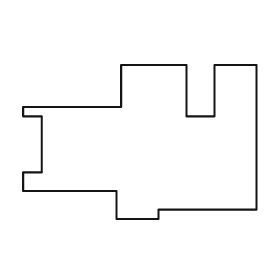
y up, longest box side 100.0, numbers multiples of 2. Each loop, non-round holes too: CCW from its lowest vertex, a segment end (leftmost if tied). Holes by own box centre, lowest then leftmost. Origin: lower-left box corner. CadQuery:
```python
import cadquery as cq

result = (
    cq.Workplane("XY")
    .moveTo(40.0, 0.0)
    .lineTo(58.0, 0.0)
    .lineTo(58.0, 4.0)
    .lineTo(100.0, 4.0)
    .lineTo(100.0, 66.0)
    .lineTo(82.0, 66.0)
    .lineTo(82.0, 44.0)
    .lineTo(70.0, 44.0)
    .lineTo(70.0, 66.0)
    .lineTo(42.0, 66.0)
    .lineTo(42.0, 48.0)
    .lineTo(0.0, 48.0)
    .lineTo(0.0, 44.0)
    .lineTo(8.0, 44.0)
    .lineTo(8.0, 20.0)
    .lineTo(0.0, 20.0)
    .lineTo(0.0, 12.0)
    .lineTo(40.0, 12.0)
    .close()
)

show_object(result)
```